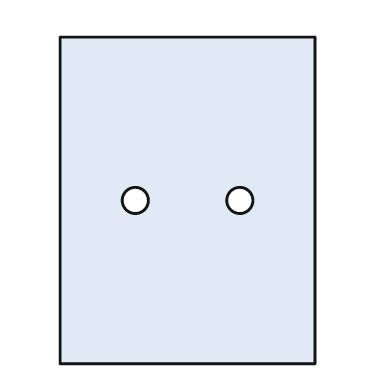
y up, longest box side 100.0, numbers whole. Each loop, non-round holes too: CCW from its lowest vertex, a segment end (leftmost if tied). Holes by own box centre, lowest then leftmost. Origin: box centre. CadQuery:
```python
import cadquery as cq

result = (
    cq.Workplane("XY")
    .moveTo(-39.0, -50.0)
    .lineTo(39.0, -50.0)
    .lineTo(39.0, 50.0)
    .lineTo(-39.0, 50.0)
    .close()
    .moveTo(-16.0, 0.0)
    .circle(4.0)
    .moveTo(16.0, 0.0)
    .circle(4.0)
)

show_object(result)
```